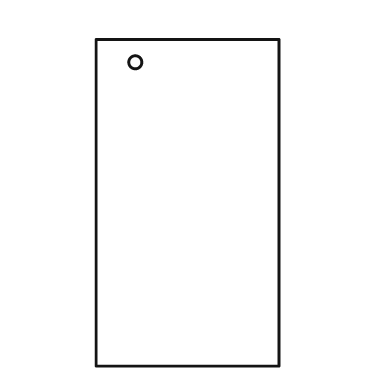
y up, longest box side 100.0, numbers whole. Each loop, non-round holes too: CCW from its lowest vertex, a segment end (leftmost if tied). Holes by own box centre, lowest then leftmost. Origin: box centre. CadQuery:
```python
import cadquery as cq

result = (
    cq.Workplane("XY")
    .moveTo(-28.0, -50.0)
    .lineTo(28.0, -50.0)
    .lineTo(28.0, 50.0)
    .lineTo(-28.0, 50.0)
    .close()
    .moveTo(-16.0, 43.0)
    .circle(2.0)
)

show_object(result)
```